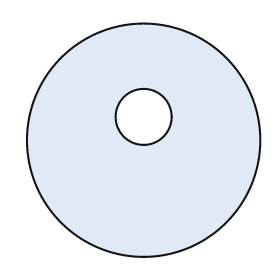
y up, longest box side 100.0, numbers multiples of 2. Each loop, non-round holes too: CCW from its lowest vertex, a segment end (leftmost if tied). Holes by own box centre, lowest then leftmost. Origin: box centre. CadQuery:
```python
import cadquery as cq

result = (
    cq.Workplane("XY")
    .moveTo(0.0, 0.0)
    .circle(50.0)
    .moveTo(0.0, 10.0)
    .circle(12.0)
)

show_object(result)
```